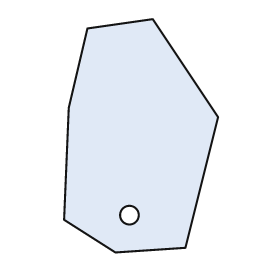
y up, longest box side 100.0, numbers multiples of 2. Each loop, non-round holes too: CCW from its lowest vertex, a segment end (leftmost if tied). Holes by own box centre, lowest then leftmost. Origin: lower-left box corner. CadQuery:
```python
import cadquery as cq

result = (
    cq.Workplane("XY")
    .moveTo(22.0, 0.0)
    .lineTo(52.0, 2.0)
    .lineTo(66.0, 58.0)
    .lineTo(38.0, 100.0)
    .lineTo(10.0, 96.0)
    .lineTo(2.0, 62.0)
    .lineTo(0.0, 14.0)
    .close()
    .moveTo(28.0, 16.0)
    .circle(4.0)
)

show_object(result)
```